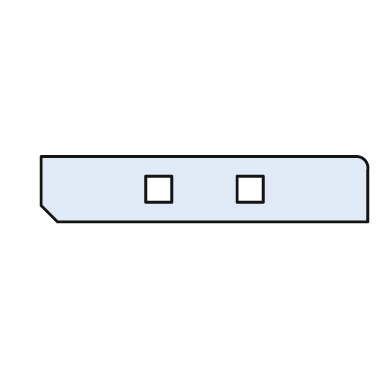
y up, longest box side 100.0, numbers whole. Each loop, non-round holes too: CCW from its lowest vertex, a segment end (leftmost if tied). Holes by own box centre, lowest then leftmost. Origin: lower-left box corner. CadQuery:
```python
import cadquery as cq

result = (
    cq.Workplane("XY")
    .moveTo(5.0, 0.0)
    .lineTo(100.0, 0.0)
    .lineTo(100.0, 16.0)
    .threePointArc((99.0, 19.0), (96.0, 20.0))
    .lineTo(0.0, 20.0)
    .lineTo(0.0, 5.0)
    .close()
    .moveTo(32.0, 6.0)
    .lineTo(40.0, 6.0)
    .lineTo(40.0, 14.0)
    .lineTo(32.0, 14.0)
    .close()
    .moveTo(60.0, 6.0)
    .lineTo(68.0, 6.0)
    .lineTo(68.0, 14.0)
    .lineTo(60.0, 14.0)
    .close()
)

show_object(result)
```